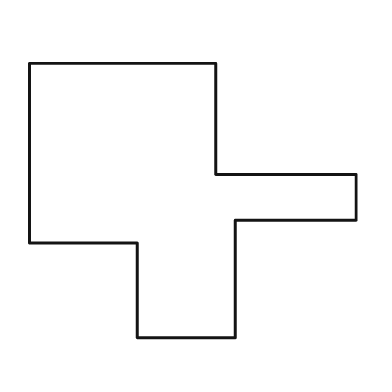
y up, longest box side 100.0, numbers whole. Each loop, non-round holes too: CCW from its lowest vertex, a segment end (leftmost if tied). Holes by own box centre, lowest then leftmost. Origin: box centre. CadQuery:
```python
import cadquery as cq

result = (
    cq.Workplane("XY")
    .moveTo(-17.0, -42.0)
    .lineTo(13.0, -42.0)
    .lineTo(13.0, -6.0)
    .lineTo(50.0, -6.0)
    .lineTo(50.0, 8.0)
    .lineTo(7.0, 8.0)
    .lineTo(7.0, 42.0)
    .lineTo(-50.0, 42.0)
    .lineTo(-50.0, -13.0)
    .lineTo(-17.0, -13.0)
    .close()
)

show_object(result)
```